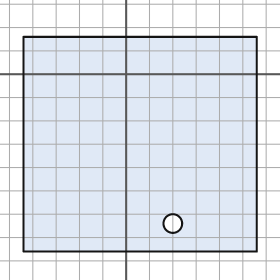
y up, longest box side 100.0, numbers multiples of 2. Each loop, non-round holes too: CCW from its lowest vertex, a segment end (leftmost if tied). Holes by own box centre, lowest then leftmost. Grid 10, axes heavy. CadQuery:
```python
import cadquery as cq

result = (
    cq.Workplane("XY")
    .moveTo(-44.0, -76.0)
    .lineTo(56.0, -76.0)
    .lineTo(56.0, 16.0)
    .lineTo(-44.0, 16.0)
    .close()
    .moveTo(20.0, -64.0)
    .circle(4.0)
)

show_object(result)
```